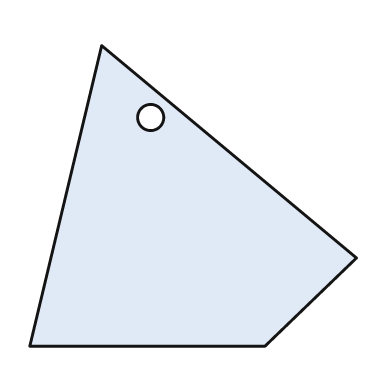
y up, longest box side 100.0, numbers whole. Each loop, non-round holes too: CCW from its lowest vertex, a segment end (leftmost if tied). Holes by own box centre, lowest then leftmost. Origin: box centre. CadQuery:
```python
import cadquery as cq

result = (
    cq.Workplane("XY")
    .moveTo(-50.0, -46.0)
    .lineTo(22.0, -46.0)
    .lineTo(50.0, -19.0)
    .lineTo(-28.0, 46.0)
    .close()
    .moveTo(-13.0, 24.0)
    .circle(4.0)
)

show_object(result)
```